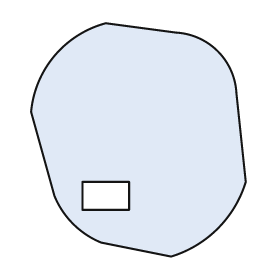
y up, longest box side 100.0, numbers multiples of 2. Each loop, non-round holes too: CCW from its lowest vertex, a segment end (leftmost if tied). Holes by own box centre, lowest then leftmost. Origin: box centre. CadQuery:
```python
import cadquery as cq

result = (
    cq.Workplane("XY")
    .moveTo(14.0, -50.0)
    .threePointArc((34.0, -38.0), (46.0, -18.0))
    .lineTo(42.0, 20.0)
    .threePointArc((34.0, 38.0), (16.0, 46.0))
    .lineTo(-14.0, 50.0)
    .threePointArc((-36.0, 36.0), (-46.0, 12.0))
    .lineTo(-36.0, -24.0)
    .threePointArc((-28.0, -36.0), (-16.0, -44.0))
    .close()
    .moveTo(-24.0, -30.0)
    .lineTo(-4.0, -30.0)
    .lineTo(-4.0, -18.0)
    .lineTo(-24.0, -18.0)
    .close()
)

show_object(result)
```